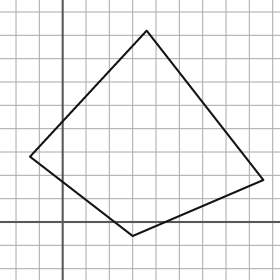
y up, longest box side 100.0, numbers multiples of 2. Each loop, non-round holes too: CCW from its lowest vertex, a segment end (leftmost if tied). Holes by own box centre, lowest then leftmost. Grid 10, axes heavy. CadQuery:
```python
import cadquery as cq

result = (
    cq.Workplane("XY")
    .moveTo(30.0, -6.0)
    .lineTo(86.0, 18.0)
    .lineTo(36.0, 82.0)
    .lineTo(-14.0, 28.0)
    .close()
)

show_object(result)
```